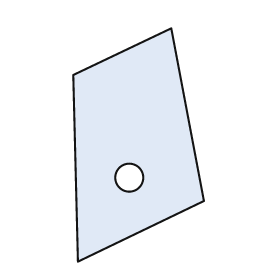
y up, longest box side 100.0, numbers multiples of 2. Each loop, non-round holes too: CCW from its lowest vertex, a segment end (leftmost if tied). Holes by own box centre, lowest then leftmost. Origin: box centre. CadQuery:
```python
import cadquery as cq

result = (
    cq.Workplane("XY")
    .moveTo(-26.0, -50.0)
    .lineTo(28.0, -24.0)
    .lineTo(14.0, 50.0)
    .lineTo(-28.0, 30.0)
    .close()
    .moveTo(-4.0, -14.0)
    .circle(6.0)
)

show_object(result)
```